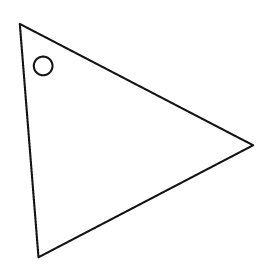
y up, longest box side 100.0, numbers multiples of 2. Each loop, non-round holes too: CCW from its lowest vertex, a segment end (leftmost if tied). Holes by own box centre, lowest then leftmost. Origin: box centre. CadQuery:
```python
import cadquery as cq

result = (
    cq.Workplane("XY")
    .moveTo(-42.0, -50.0)
    .lineTo(50.0, -2.0)
    .lineTo(-50.0, 50.0)
    .close()
    .moveTo(-40.0, 32.0)
    .circle(4.0)
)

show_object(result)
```